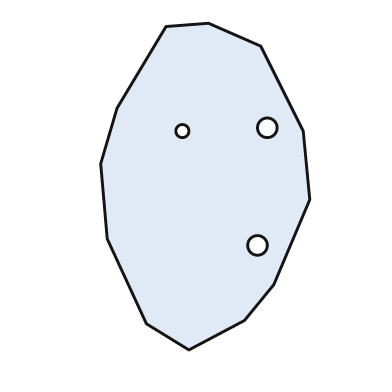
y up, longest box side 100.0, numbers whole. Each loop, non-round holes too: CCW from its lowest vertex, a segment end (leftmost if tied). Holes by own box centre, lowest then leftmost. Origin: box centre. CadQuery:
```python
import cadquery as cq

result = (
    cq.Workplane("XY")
    .moveTo(-5.0, -50.0)
    .lineTo(12.0, -41.0)
    .lineTo(21.0, -30.0)
    .lineTo(32.0, -4.0)
    .lineTo(30.0, 17.0)
    .lineTo(17.0, 43.0)
    .lineTo(1.0, 50.0)
    .lineTo(-12.0, 49.0)
    .lineTo(-27.0, 24.0)
    .lineTo(-32.0, 7.0)
    .lineTo(-30.0, -16.0)
    .lineTo(-18.0, -42.0)
    .close()
    .moveTo(16.0, -18.0)
    .circle(3.0)
    .moveTo(-7.0, 17.0)
    .circle(2.0)
    .moveTo(19.0, 18.0)
    .circle(3.0)
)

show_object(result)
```